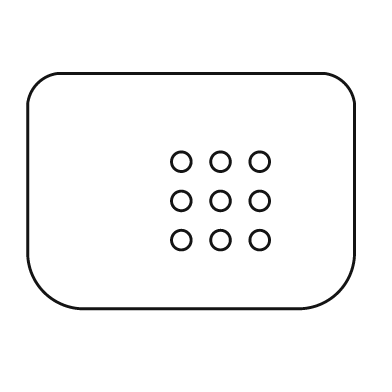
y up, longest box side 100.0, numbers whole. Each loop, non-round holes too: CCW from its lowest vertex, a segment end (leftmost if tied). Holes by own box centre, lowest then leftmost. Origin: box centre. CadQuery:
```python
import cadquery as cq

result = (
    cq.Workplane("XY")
    .moveTo(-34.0, -36.0)
    .lineTo(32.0, -36.0)
    .threePointArc((45.0, -31.0), (50.0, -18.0))
    .lineTo(50.0, 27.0)
    .threePointArc((47.0, 33.0), (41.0, 36.0))
    .lineTo(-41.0, 36.0)
    .threePointArc((-47.0, 33.0), (-50.0, 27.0))
    .lineTo(-50.0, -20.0)
    .threePointArc((-45.0, -31.0), (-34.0, -36.0))
    .close()
    .moveTo(-3.0, -15.0)
    .circle(3.0)
    .moveTo(9.0, -15.0)
    .circle(3.0)
    .moveTo(21.0, -15.0)
    .circle(3.0)
    .moveTo(-3.0, -3.0)
    .circle(3.0)
    .moveTo(9.0, -3.0)
    .circle(3.0)
    .moveTo(21.0, -3.0)
    .circle(3.0)
    .moveTo(-3.0, 9.0)
    .circle(3.0)
    .moveTo(9.0, 9.0)
    .circle(3.0)
    .moveTo(21.0, 9.0)
    .circle(3.0)
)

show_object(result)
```